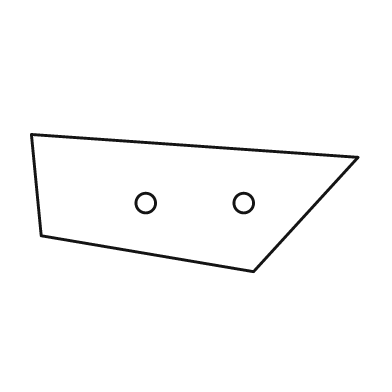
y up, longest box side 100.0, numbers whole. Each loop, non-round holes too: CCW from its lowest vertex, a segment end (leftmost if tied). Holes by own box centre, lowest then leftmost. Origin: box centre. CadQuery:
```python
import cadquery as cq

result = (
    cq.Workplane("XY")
    .moveTo(18.0, -21.0)
    .lineTo(50.0, 14.0)
    .lineTo(-50.0, 21.0)
    .lineTo(-47.0, -10.0)
    .close()
    .moveTo(-15.0, 0.0)
    .circle(3.0)
    .moveTo(15.0, 0.0)
    .circle(3.0)
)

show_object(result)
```